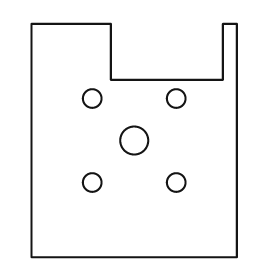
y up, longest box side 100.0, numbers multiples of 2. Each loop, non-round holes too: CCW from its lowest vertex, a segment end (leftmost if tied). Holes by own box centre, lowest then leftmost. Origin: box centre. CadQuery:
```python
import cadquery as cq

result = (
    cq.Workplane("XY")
    .moveTo(-44.0, -50.0)
    .lineTo(44.0, -50.0)
    .lineTo(44.0, 50.0)
    .lineTo(38.0, 50.0)
    .lineTo(38.0, 26.0)
    .lineTo(-10.0, 26.0)
    .lineTo(-10.0, 50.0)
    .lineTo(-44.0, 50.0)
    .close()
    .moveTo(-18.0, -18.0)
    .circle(4.0)
    .moveTo(18.0, -18.0)
    .circle(4.0)
    .moveTo(0.0, 0.0)
    .circle(6.0)
    .moveTo(-18.0, 18.0)
    .circle(4.0)
    .moveTo(18.0, 18.0)
    .circle(4.0)
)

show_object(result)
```